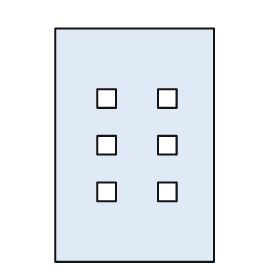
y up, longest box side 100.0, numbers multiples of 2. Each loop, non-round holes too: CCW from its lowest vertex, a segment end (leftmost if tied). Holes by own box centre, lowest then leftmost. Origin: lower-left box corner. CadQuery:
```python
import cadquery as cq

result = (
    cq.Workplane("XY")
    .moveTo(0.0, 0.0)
    .lineTo(68.0, 0.0)
    .lineTo(68.0, 100.0)
    .lineTo(0.0, 100.0)
    .close()
    .moveTo(18.0, 26.0)
    .lineTo(26.0, 26.0)
    .lineTo(26.0, 34.0)
    .lineTo(18.0, 34.0)
    .close()
    .moveTo(44.0, 26.0)
    .lineTo(52.0, 26.0)
    .lineTo(52.0, 34.0)
    .lineTo(44.0, 34.0)
    .close()
    .moveTo(18.0, 46.0)
    .lineTo(26.0, 46.0)
    .lineTo(26.0, 54.0)
    .lineTo(18.0, 54.0)
    .close()
    .moveTo(44.0, 46.0)
    .lineTo(52.0, 46.0)
    .lineTo(52.0, 54.0)
    .lineTo(44.0, 54.0)
    .close()
    .moveTo(18.0, 66.0)
    .lineTo(26.0, 66.0)
    .lineTo(26.0, 74.0)
    .lineTo(18.0, 74.0)
    .close()
    .moveTo(44.0, 66.0)
    .lineTo(52.0, 66.0)
    .lineTo(52.0, 74.0)
    .lineTo(44.0, 74.0)
    .close()
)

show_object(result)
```